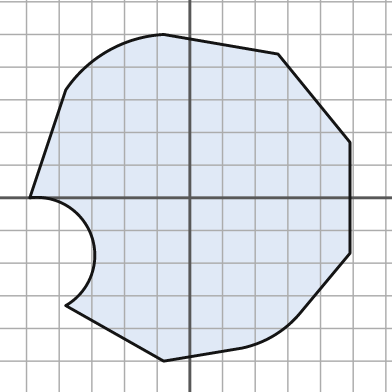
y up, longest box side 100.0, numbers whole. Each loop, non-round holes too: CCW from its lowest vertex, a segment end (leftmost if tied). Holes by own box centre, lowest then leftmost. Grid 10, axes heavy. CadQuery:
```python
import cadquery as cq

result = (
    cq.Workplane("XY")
    .moveTo(-8.0, -50.0)
    .lineTo(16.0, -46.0)
    .threePointArc((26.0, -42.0), (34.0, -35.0))
    .lineTo(49.0, -17.0)
    .lineTo(49.0, 17.0)
    .lineTo(27.0, 44.0)
    .lineTo(-8.0, 50.0)
    .threePointArc((-25.0, 45.0), (-38.0, 33.0))
    .lineTo(-49.0, 0.0)
    .threePointArc((-30.0, -12.0), (-38.0, -33.0))
    .close()
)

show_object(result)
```